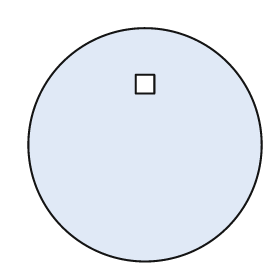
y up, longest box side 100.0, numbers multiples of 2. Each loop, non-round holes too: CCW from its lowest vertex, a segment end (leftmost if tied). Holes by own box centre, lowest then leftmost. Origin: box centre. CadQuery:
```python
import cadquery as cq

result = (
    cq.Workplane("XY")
    .moveTo(0.0, 0.0)
    .circle(50.0)
    .moveTo(-4.0, 22.0)
    .lineTo(4.0, 22.0)
    .lineTo(4.0, 30.0)
    .lineTo(-4.0, 30.0)
    .close()
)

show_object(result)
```